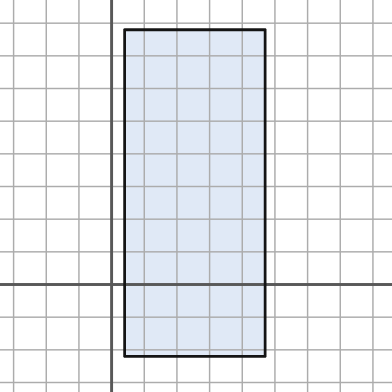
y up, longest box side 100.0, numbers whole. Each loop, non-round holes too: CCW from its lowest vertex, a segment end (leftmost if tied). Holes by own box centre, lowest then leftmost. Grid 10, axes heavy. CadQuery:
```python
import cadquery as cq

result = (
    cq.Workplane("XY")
    .moveTo(4.0, -22.0)
    .lineTo(47.0, -22.0)
    .lineTo(47.0, 78.0)
    .lineTo(4.0, 78.0)
    .close()
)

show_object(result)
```